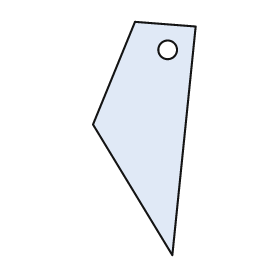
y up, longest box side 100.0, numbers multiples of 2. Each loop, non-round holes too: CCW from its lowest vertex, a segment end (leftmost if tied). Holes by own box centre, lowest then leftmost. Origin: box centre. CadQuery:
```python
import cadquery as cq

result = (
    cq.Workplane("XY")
    .moveTo(12.0, -50.0)
    .lineTo(22.0, 48.0)
    .lineTo(-4.0, 50.0)
    .lineTo(-22.0, 6.0)
    .close()
    .moveTo(10.0, 38.0)
    .circle(4.0)
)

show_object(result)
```